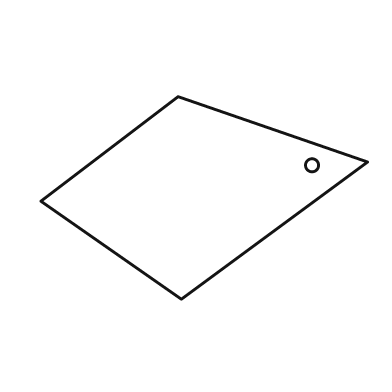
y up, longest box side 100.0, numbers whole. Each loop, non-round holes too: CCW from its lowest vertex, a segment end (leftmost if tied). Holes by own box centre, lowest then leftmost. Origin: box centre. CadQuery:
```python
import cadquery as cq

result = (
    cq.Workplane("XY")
    .moveTo(-7.0, -31.0)
    .lineTo(50.0, 11.0)
    .lineTo(-8.0, 31.0)
    .lineTo(-50.0, -1.0)
    .close()
    .moveTo(33.0, 10.0)
    .circle(2.0)
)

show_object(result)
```